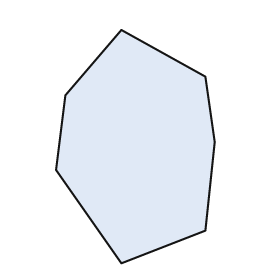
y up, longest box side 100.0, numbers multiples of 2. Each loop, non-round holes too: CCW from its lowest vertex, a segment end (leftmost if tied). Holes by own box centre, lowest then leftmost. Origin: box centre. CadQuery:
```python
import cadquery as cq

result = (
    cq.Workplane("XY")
    .moveTo(-6.0, -50.0)
    .lineTo(30.0, -36.0)
    .lineTo(34.0, 2.0)
    .lineTo(30.0, 30.0)
    .lineTo(-6.0, 50.0)
    .lineTo(-30.0, 22.0)
    .lineTo(-34.0, -10.0)
    .close()
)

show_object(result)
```